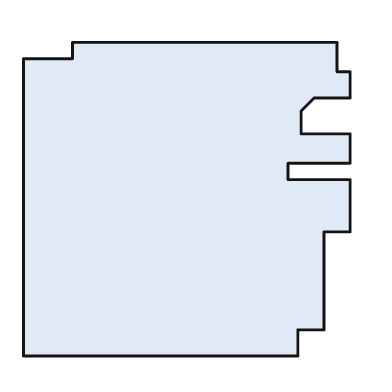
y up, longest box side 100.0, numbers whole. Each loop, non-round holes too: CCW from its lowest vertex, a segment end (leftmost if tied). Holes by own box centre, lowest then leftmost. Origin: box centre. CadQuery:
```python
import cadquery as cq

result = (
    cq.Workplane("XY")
    .moveTo(-50.0, -48.0)
    .lineTo(34.0, -48.0)
    .lineTo(34.0, -40.0)
    .lineTo(42.0, -40.0)
    .lineTo(42.0, -10.0)
    .lineTo(50.0, -10.0)
    .lineTo(50.0, 6.0)
    .lineTo(31.0, 6.0)
    .lineTo(31.0, 11.0)
    .lineTo(50.0, 11.0)
    .lineTo(50.0, 20.0)
    .lineTo(35.0, 20.0)
    .lineTo(35.0, 27.0)
    .lineTo(39.0, 31.0)
    .lineTo(50.0, 31.0)
    .lineTo(50.0, 39.0)
    .lineTo(46.0, 39.0)
    .lineTo(46.0, 48.0)
    .lineTo(-35.0, 48.0)
    .lineTo(-35.0, 43.0)
    .lineTo(-50.0, 43.0)
    .close()
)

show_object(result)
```